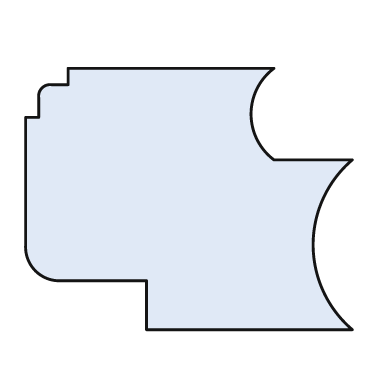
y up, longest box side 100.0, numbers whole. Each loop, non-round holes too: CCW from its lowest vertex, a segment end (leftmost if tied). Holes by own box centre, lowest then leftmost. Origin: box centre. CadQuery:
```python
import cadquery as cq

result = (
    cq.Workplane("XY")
    .moveTo(-13.0, -40.0)
    .lineTo(50.0, -40.0)
    .threePointArc((38.0, -14.0), (50.0, 12.0))
    .lineTo(26.0, 12.0)
    .threePointArc((19.0, 26.0), (26.0, 40.0))
    .lineTo(-37.0, 40.0)
    .lineTo(-37.0, 35.0)
    .lineTo(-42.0, 35.0)
    .threePointArc((-45.0, 34.0), (-46.0, 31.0))
    .lineTo(-46.0, 25.0)
    .lineTo(-50.0, 25.0)
    .lineTo(-50.0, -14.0)
    .threePointArc((-47.0, -22.0), (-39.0, -25.0))
    .lineTo(-13.0, -25.0)
    .close()
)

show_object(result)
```